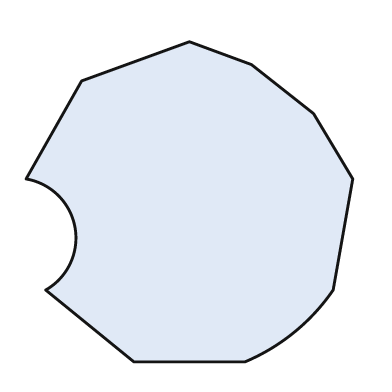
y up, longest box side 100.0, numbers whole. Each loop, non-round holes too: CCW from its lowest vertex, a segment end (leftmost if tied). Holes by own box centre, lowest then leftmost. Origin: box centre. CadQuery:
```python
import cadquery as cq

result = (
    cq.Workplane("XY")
    .moveTo(-17.0, -49.0)
    .lineTo(17.0, -49.0)
    .threePointArc((32.0, -40.0), (44.0, -27.0))
    .lineTo(50.0, 7.0)
    .lineTo(38.0, 27.0)
    .lineTo(19.0, 42.0)
    .lineTo(0.0, 49.0)
    .lineTo(-33.0, 37.0)
    .lineTo(-50.0, 7.0)
    .threePointArc((-35.0, -8.0), (-44.0, -27.0))
    .close()
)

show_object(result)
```